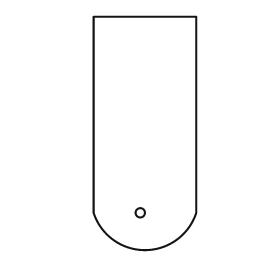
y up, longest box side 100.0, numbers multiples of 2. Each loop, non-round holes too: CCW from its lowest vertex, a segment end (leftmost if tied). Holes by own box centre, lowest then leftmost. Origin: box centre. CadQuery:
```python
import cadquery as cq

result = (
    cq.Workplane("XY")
    .moveTo(-22.0, -34.0)
    .threePointArc((0.0, -50.0), (22.0, -34.0))
    .lineTo(22.0, 50.0)
    .lineTo(-22.0, 50.0)
    .close()
    .moveTo(-2.0, -34.0)
    .circle(2.0)
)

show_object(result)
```